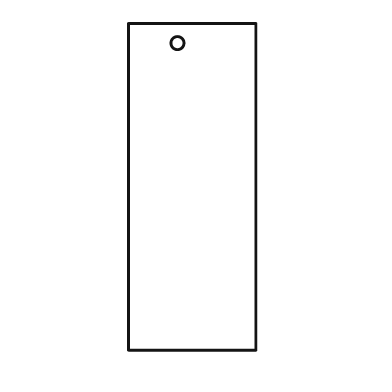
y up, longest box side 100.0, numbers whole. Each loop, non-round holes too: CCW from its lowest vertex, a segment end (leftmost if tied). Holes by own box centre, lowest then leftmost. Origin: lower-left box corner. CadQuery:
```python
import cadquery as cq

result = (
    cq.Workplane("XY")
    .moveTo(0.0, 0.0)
    .lineTo(39.0, 0.0)
    .lineTo(39.0, 100.0)
    .lineTo(0.0, 100.0)
    .close()
    .moveTo(15.0, 94.0)
    .circle(2.0)
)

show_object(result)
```